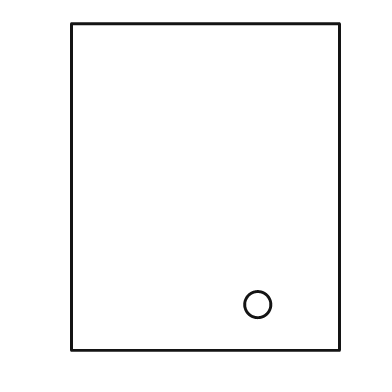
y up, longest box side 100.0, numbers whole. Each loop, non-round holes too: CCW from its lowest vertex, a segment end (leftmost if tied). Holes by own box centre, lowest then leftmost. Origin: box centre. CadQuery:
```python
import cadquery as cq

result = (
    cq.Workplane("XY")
    .moveTo(-41.0, -50.0)
    .lineTo(41.0, -50.0)
    .lineTo(41.0, 50.0)
    .lineTo(-41.0, 50.0)
    .close()
    .moveTo(16.0, -36.0)
    .circle(4.0)
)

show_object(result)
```